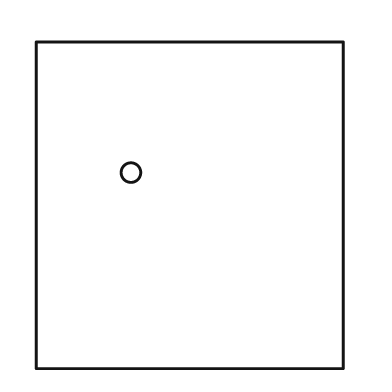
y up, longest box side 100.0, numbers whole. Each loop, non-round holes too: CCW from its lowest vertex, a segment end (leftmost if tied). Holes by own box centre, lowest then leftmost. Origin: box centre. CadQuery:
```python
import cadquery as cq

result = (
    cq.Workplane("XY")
    .moveTo(-47.0, -50.0)
    .lineTo(47.0, -50.0)
    .lineTo(47.0, 50.0)
    .lineTo(-47.0, 50.0)
    .close()
    .moveTo(-18.0, 10.0)
    .circle(3.0)
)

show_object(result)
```